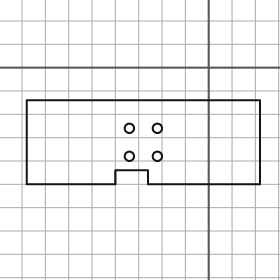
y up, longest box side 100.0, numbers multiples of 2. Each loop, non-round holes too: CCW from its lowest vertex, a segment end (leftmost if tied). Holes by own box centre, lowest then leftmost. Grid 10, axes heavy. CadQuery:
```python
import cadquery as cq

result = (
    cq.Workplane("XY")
    .moveTo(-78.0, -50.0)
    .lineTo(-40.0, -50.0)
    .lineTo(-40.0, -44.0)
    .lineTo(-26.0, -44.0)
    .lineTo(-26.0, -50.0)
    .lineTo(22.0, -50.0)
    .lineTo(22.0, -14.0)
    .lineTo(-78.0, -14.0)
    .close()
    .moveTo(-34.0, -38.0)
    .circle(2.0)
    .moveTo(-22.0, -38.0)
    .circle(2.0)
    .moveTo(-34.0, -26.0)
    .circle(2.0)
    .moveTo(-22.0, -26.0)
    .circle(2.0)
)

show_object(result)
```